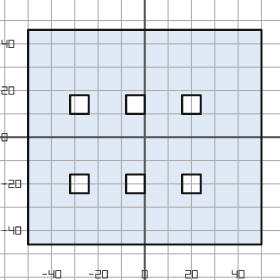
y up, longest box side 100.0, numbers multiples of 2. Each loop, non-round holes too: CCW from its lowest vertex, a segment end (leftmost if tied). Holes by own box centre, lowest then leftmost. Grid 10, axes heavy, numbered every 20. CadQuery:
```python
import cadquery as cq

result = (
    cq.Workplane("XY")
    .moveTo(-50.0, -46.0)
    .lineTo(50.0, -46.0)
    .lineTo(50.0, 46.0)
    .lineTo(-50.0, 46.0)
    .close()
    .moveTo(-32.0, -24.0)
    .lineTo(-24.0, -24.0)
    .lineTo(-24.0, -16.0)
    .lineTo(-32.0, -16.0)
    .close()
    .moveTo(-8.0, -24.0)
    .lineTo(0.0, -24.0)
    .lineTo(0.0, -16.0)
    .lineTo(-8.0, -16.0)
    .close()
    .moveTo(16.0, -24.0)
    .lineTo(24.0, -24.0)
    .lineTo(24.0, -16.0)
    .lineTo(16.0, -16.0)
    .close()
    .moveTo(-32.0, 10.0)
    .lineTo(-24.0, 10.0)
    .lineTo(-24.0, 18.0)
    .lineTo(-32.0, 18.0)
    .close()
    .moveTo(-8.0, 10.0)
    .lineTo(0.0, 10.0)
    .lineTo(0.0, 18.0)
    .lineTo(-8.0, 18.0)
    .close()
    .moveTo(16.0, 10.0)
    .lineTo(24.0, 10.0)
    .lineTo(24.0, 18.0)
    .lineTo(16.0, 18.0)
    .close()
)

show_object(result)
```